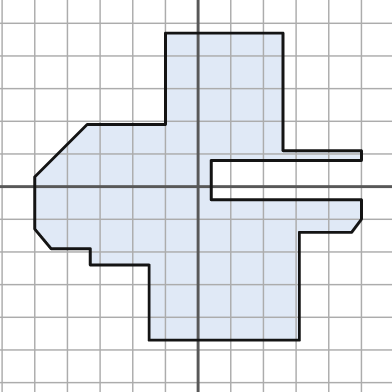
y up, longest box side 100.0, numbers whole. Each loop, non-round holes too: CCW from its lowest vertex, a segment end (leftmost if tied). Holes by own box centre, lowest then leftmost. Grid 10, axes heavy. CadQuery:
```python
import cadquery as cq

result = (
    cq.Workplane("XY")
    .moveTo(-15.0, -47.0)
    .lineTo(31.0, -47.0)
    .lineTo(31.0, -14.0)
    .lineTo(47.0, -14.0)
    .lineTo(50.0, -10.0)
    .lineTo(50.0, -4.0)
    .lineTo(4.0, -4.0)
    .lineTo(4.0, 8.0)
    .lineTo(50.0, 8.0)
    .lineTo(50.0, 11.0)
    .lineTo(26.0, 11.0)
    .lineTo(26.0, 47.0)
    .lineTo(-10.0, 47.0)
    .lineTo(-10.0, 19.0)
    .lineTo(-34.0, 19.0)
    .lineTo(-50.0, 3.0)
    .lineTo(-50.0, -13.0)
    .lineTo(-45.0, -19.0)
    .lineTo(-33.0, -19.0)
    .lineTo(-33.0, -24.0)
    .lineTo(-15.0, -24.0)
    .close()
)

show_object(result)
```